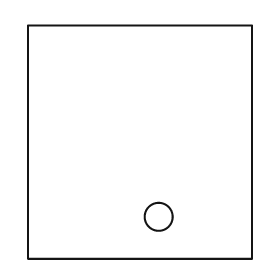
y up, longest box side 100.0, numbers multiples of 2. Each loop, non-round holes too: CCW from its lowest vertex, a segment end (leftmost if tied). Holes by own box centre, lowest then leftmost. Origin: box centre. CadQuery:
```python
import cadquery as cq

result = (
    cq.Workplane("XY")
    .moveTo(-48.0, -50.0)
    .lineTo(48.0, -50.0)
    .lineTo(48.0, 50.0)
    .lineTo(-48.0, 50.0)
    .close()
    .moveTo(8.0, -32.0)
    .circle(6.0)
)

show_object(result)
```